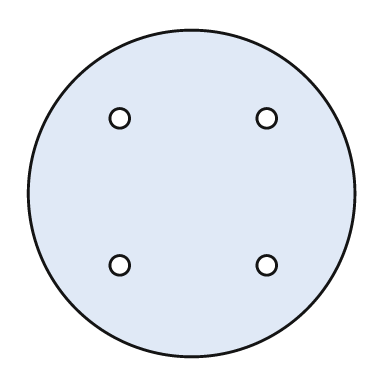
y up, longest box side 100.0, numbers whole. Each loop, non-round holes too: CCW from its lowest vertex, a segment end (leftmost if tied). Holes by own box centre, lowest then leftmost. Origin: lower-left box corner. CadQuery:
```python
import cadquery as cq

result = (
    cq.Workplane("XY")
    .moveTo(50.0, 50.0)
    .circle(50.0)
    .moveTo(28.0, 28.0)
    .circle(3.0)
    .moveTo(73.0, 28.0)
    .circle(3.0)
    .moveTo(28.0, 73.0)
    .circle(3.0)
    .moveTo(73.0, 73.0)
    .circle(3.0)
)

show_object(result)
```